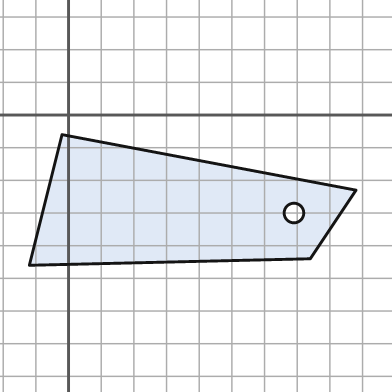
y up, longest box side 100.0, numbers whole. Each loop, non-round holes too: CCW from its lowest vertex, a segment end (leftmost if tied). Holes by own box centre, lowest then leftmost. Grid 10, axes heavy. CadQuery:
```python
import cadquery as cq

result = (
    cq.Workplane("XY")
    .moveTo(-12.0, -46.0)
    .lineTo(74.0, -44.0)
    .lineTo(88.0, -23.0)
    .lineTo(-2.0, -6.0)
    .close()
    .moveTo(69.0, -30.0)
    .circle(3.0)
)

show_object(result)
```